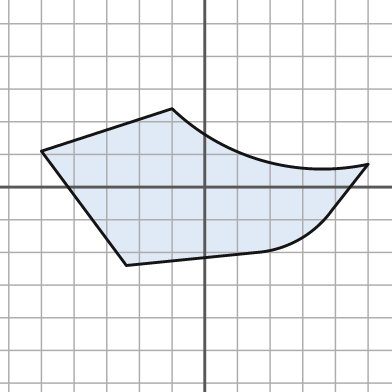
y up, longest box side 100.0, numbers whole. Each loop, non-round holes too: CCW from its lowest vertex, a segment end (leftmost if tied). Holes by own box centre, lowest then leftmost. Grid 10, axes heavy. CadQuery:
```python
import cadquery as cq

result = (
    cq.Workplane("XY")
    .moveTo(-24.0, -24.0)
    .lineTo(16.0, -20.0)
    .threePointArc((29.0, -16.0), (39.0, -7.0))
    .lineTo(50.0, 7.0)
    .threePointArc((18.0, 8.0), (-10.0, 24.0))
    .lineTo(-50.0, 11.0)
    .close()
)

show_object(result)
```